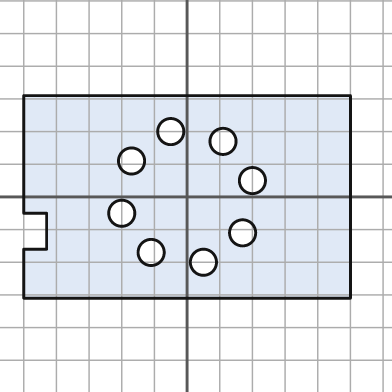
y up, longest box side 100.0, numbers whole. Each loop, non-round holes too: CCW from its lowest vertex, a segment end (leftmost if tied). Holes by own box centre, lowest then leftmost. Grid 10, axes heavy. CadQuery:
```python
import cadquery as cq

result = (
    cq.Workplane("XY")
    .moveTo(-50.0, -31.0)
    .lineTo(50.0, -31.0)
    .lineTo(50.0, 31.0)
    .lineTo(-50.0, 31.0)
    .lineTo(-50.0, -5.0)
    .lineTo(-43.0, -5.0)
    .lineTo(-43.0, -16.0)
    .lineTo(-50.0, -16.0)
    .close()
    .moveTo(5.0, -20.0)
    .circle(4.0)
    .moveTo(-11.0, -17.0)
    .circle(4.0)
    .moveTo(17.0, -11.0)
    .circle(4.0)
    .moveTo(-20.0, -5.0)
    .circle(4.0)
    .moveTo(20.0, 5.0)
    .circle(4.0)
    .moveTo(-17.0, 11.0)
    .circle(4.0)
    .moveTo(11.0, 17.0)
    .circle(4.0)
    .moveTo(-5.0, 20.0)
    .circle(4.0)
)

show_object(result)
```